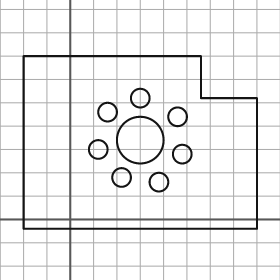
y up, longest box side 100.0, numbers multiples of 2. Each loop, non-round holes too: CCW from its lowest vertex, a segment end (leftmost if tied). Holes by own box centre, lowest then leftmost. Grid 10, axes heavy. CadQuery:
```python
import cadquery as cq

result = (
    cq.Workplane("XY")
    .moveTo(-20.0, -4.0)
    .lineTo(80.0, -4.0)
    .lineTo(80.0, 52.0)
    .lineTo(56.0, 52.0)
    .lineTo(56.0, 70.0)
    .lineTo(-20.0, 70.0)
    .close()
    .moveTo(38.0, 16.0)
    .circle(4.0)
    .moveTo(22.0, 18.0)
    .circle(4.0)
    .moveTo(48.0, 28.0)
    .circle(4.0)
    .moveTo(12.0, 30.0)
    .circle(4.0)
    .moveTo(30.0, 34.0)
    .circle(10.0)
    .moveTo(46.0, 44.0)
    .circle(4.0)
    .moveTo(16.0, 46.0)
    .circle(4.0)
    .moveTo(30.0, 52.0)
    .circle(4.0)
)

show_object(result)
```